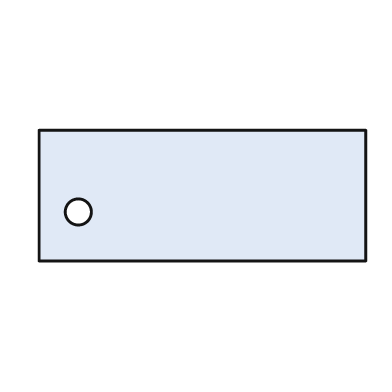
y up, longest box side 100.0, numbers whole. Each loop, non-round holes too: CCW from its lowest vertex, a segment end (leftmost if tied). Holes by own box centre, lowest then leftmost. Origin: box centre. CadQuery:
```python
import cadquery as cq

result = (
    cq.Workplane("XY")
    .moveTo(-50.0, -20.0)
    .lineTo(50.0, -20.0)
    .lineTo(50.0, 20.0)
    .lineTo(-50.0, 20.0)
    .close()
    .moveTo(-38.0, -5.0)
    .circle(4.0)
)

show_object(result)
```